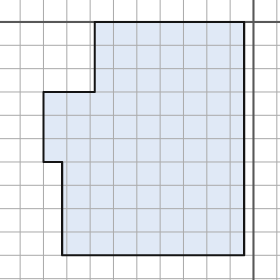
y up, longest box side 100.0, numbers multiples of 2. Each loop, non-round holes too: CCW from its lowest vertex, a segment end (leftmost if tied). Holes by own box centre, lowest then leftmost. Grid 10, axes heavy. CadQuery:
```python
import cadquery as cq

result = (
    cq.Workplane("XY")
    .moveTo(-82.0, -100.0)
    .lineTo(-4.0, -100.0)
    .lineTo(-4.0, 0.0)
    .lineTo(-68.0, 0.0)
    .lineTo(-68.0, -30.0)
    .lineTo(-90.0, -30.0)
    .lineTo(-90.0, -60.0)
    .lineTo(-82.0, -60.0)
    .close()
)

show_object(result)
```